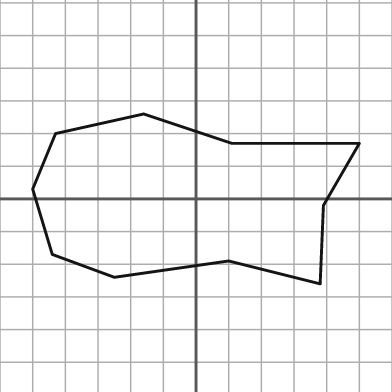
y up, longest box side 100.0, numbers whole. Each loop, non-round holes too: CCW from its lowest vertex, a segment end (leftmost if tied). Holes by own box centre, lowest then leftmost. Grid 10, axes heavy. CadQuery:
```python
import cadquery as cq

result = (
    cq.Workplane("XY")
    .moveTo(38.0, -26.0)
    .lineTo(39.0, -2.0)
    .lineTo(50.0, 17.0)
    .lineTo(11.0, 17.0)
    .lineTo(-16.0, 26.0)
    .lineTo(-43.0, 20.0)
    .lineTo(-50.0, 3.0)
    .lineTo(-44.0, -17.0)
    .lineTo(-25.0, -24.0)
    .lineTo(10.0, -19.0)
    .close()
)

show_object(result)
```